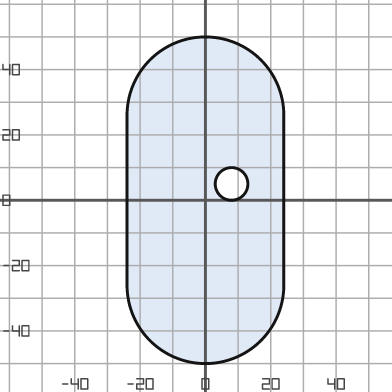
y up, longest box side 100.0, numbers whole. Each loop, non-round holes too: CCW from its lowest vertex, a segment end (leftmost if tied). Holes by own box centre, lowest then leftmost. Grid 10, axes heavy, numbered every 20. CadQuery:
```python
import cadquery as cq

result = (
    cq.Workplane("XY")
    .moveTo(-24.0, -26.0)
    .threePointArc((0.0, -50.0), (24.0, -26.0))
    .lineTo(24.0, 26.0)
    .threePointArc((0.0, 50.0), (-24.0, 26.0))
    .close()
    .moveTo(8.0, 5.0)
    .circle(5.0)
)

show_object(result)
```